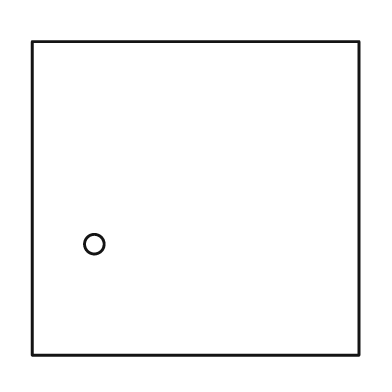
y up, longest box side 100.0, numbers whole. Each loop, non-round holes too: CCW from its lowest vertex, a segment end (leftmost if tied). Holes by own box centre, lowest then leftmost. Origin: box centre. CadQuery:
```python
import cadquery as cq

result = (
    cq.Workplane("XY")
    .moveTo(-50.0, -48.0)
    .lineTo(50.0, -48.0)
    .lineTo(50.0, 48.0)
    .lineTo(-50.0, 48.0)
    .close()
    .moveTo(-31.0, -14.0)
    .circle(3.0)
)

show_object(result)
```